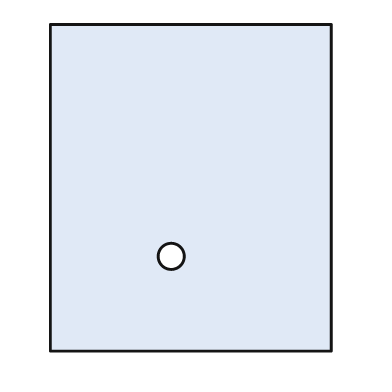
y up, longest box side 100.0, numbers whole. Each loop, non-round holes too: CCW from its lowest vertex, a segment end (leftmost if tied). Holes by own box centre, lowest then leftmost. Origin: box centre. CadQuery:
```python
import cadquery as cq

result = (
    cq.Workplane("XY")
    .moveTo(-43.0, -50.0)
    .lineTo(43.0, -50.0)
    .lineTo(43.0, 50.0)
    .lineTo(-43.0, 50.0)
    .close()
    .moveTo(-6.0, -21.0)
    .circle(4.0)
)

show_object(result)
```